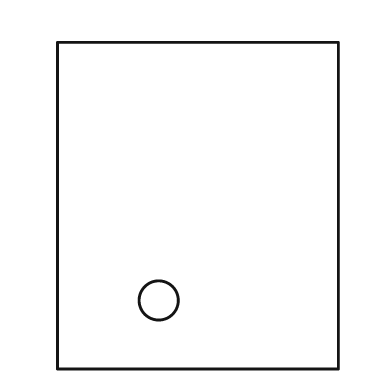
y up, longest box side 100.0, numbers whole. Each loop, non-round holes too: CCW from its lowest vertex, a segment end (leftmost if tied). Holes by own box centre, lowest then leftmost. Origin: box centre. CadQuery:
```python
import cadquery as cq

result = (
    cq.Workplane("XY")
    .moveTo(-43.0, -50.0)
    .lineTo(43.0, -50.0)
    .lineTo(43.0, 50.0)
    .lineTo(-43.0, 50.0)
    .close()
    .moveTo(-12.0, -29.0)
    .circle(6.0)
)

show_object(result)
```